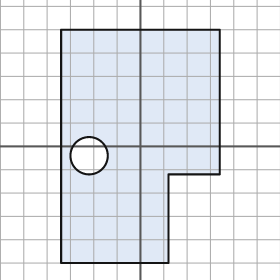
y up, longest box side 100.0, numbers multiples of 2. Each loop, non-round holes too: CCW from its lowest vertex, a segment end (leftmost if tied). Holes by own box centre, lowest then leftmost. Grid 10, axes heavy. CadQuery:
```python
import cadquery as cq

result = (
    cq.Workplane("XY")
    .moveTo(-34.0, -50.0)
    .lineTo(12.0, -50.0)
    .lineTo(12.0, -12.0)
    .lineTo(34.0, -12.0)
    .lineTo(34.0, 50.0)
    .lineTo(-34.0, 50.0)
    .close()
    .moveTo(-22.0, -4.0)
    .circle(8.0)
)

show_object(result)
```